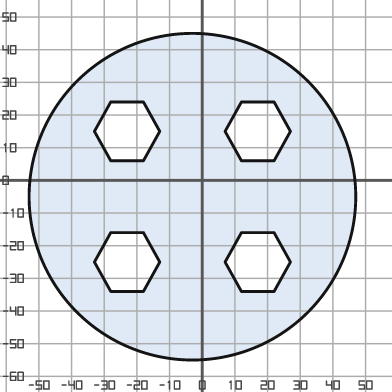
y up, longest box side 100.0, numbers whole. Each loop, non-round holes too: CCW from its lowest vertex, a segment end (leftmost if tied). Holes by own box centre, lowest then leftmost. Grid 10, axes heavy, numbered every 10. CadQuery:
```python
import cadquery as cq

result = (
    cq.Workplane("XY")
    .moveTo(-3.0, -5.0)
    .circle(50.0)
    .moveTo(-28.0, -34.0)
    .lineTo(-18.0, -34.0)
    .lineTo(-13.0, -25.0)
    .lineTo(-18.0, -16.0)
    .lineTo(-28.0, -16.0)
    .lineTo(-33.0, -25.0)
    .close()
    .moveTo(12.0, -34.0)
    .lineTo(22.0, -34.0)
    .lineTo(27.0, -25.0)
    .lineTo(22.0, -16.0)
    .lineTo(12.0, -16.0)
    .lineTo(7.0, -25.0)
    .close()
    .moveTo(-28.0, 6.0)
    .lineTo(-18.0, 6.0)
    .lineTo(-13.0, 15.0)
    .lineTo(-18.0, 24.0)
    .lineTo(-28.0, 24.0)
    .lineTo(-33.0, 15.0)
    .close()
    .moveTo(12.0, 6.0)
    .lineTo(22.0, 6.0)
    .lineTo(27.0, 15.0)
    .lineTo(22.0, 24.0)
    .lineTo(12.0, 24.0)
    .lineTo(7.0, 15.0)
    .close()
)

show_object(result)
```